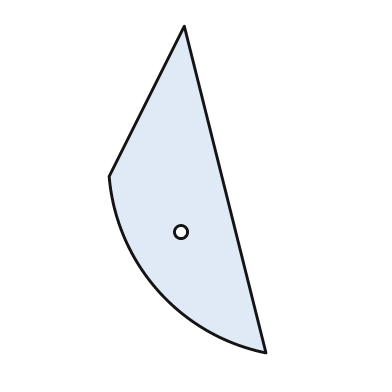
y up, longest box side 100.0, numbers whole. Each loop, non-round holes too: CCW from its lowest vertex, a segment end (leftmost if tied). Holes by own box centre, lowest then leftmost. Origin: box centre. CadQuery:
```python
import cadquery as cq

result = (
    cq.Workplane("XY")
    .moveTo(24.0, -50.0)
    .lineTo(-1.0, 50.0)
    .lineTo(-24.0, 4.0)
    .threePointArc((-9.0, -31.0), (24.0, -50.0))
    .close()
    .moveTo(-2.0, -13.0)
    .circle(2.0)
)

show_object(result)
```